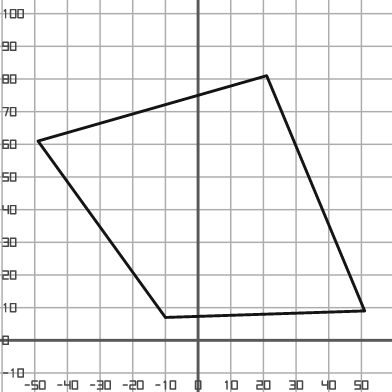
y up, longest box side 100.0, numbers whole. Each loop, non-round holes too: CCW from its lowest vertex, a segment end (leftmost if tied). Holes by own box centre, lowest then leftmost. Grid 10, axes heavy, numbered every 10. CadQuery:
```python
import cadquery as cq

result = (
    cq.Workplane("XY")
    .moveTo(-10.0, 7.0)
    .lineTo(51.0, 9.0)
    .lineTo(21.0, 81.0)
    .lineTo(-49.0, 61.0)
    .close()
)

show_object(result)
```